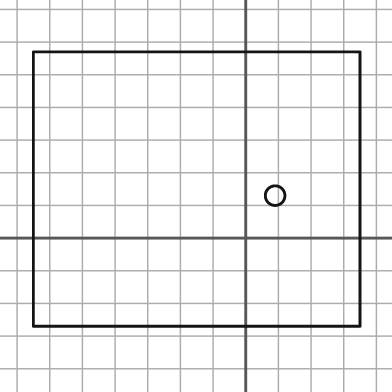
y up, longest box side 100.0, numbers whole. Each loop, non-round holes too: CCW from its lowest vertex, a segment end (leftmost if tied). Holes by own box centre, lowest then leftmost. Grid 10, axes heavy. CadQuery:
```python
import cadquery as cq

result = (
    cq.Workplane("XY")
    .moveTo(-65.0, -27.0)
    .lineTo(35.0, -27.0)
    .lineTo(35.0, 57.0)
    .lineTo(-65.0, 57.0)
    .close()
    .moveTo(9.0, 13.0)
    .circle(3.0)
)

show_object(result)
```